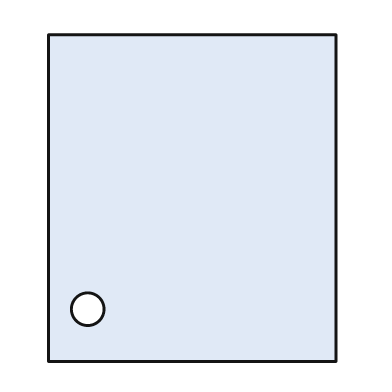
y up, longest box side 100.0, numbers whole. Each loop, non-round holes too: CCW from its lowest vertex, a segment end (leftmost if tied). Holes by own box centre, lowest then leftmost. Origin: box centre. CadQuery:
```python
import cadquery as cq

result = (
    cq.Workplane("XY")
    .moveTo(-44.0, -50.0)
    .lineTo(44.0, -50.0)
    .lineTo(44.0, 50.0)
    .lineTo(-44.0, 50.0)
    .close()
    .moveTo(-32.0, -34.0)
    .circle(5.0)
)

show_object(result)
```